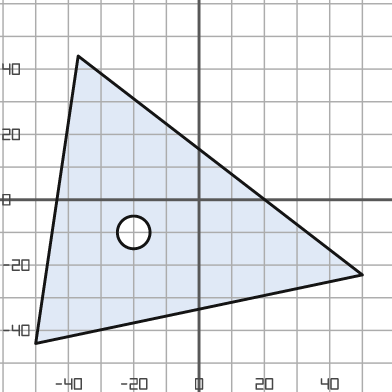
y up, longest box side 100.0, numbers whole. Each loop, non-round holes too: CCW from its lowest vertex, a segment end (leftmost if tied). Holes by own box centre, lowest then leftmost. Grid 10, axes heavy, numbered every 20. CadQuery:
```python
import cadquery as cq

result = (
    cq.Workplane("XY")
    .moveTo(-50.0, -44.0)
    .lineTo(50.0, -23.0)
    .lineTo(-37.0, 44.0)
    .close()
    .moveTo(-20.0, -10.0)
    .circle(5.0)
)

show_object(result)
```